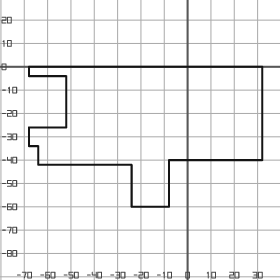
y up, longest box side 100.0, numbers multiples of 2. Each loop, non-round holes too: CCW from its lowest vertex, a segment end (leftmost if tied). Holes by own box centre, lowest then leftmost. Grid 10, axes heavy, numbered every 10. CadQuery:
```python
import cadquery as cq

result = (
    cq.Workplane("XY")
    .moveTo(-24.0, -60.0)
    .lineTo(-8.0, -60.0)
    .lineTo(-8.0, -40.0)
    .lineTo(32.0, -40.0)
    .lineTo(32.0, 0.0)
    .lineTo(-68.0, 0.0)
    .lineTo(-68.0, -4.0)
    .lineTo(-52.0, -4.0)
    .lineTo(-52.0, -26.0)
    .lineTo(-68.0, -26.0)
    .lineTo(-68.0, -34.0)
    .lineTo(-64.0, -34.0)
    .lineTo(-64.0, -42.0)
    .lineTo(-24.0, -42.0)
    .close()
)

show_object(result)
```